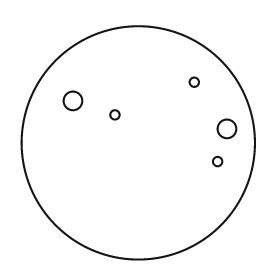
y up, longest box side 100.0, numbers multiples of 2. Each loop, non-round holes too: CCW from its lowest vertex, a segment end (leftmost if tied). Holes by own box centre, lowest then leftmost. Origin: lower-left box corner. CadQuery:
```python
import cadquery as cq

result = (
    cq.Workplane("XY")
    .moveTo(50.0, 50.0)
    .circle(50.0)
    .moveTo(84.0, 42.0)
    .circle(2.0)
    .moveTo(88.0, 56.0)
    .circle(4.0)
    .moveTo(40.0, 62.0)
    .circle(2.0)
    .moveTo(22.0, 68.0)
    .circle(4.0)
    .moveTo(74.0, 76.0)
    .circle(2.0)
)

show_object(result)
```